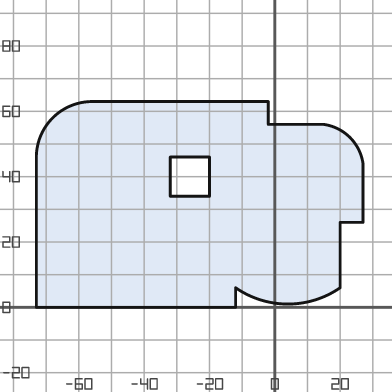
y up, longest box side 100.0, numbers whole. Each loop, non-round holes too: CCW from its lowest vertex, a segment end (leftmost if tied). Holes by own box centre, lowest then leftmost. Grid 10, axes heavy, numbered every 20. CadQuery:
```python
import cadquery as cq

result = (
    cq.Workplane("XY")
    .moveTo(-73.0, 0.0)
    .lineTo(-12.0, 0.0)
    .lineTo(-12.0, 6.0)
    .threePointArc((4.0, 1.0), (20.0, 6.0))
    .lineTo(20.0, 26.0)
    .lineTo(27.0, 26.0)
    .lineTo(27.0, 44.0)
    .threePointArc((23.0, 52.0), (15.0, 56.0))
    .lineTo(-2.0, 56.0)
    .lineTo(-2.0, 63.0)
    .lineTo(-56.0, 63.0)
    .threePointArc((-68.0, 58.0), (-73.0, 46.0))
    .close()
    .moveTo(-32.0, 34.0)
    .lineTo(-20.0, 34.0)
    .lineTo(-20.0, 46.0)
    .lineTo(-32.0, 46.0)
    .close()
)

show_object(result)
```